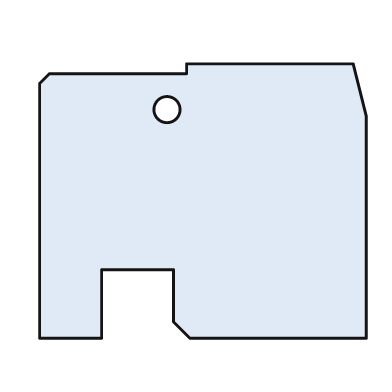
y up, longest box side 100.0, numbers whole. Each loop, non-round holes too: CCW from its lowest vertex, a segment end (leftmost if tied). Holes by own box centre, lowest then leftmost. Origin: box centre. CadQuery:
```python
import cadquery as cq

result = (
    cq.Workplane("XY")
    .moveTo(-50.0, -42.0)
    .lineTo(-31.0, -42.0)
    .lineTo(-31.0, -21.0)
    .lineTo(-9.0, -21.0)
    .lineTo(-9.0, -37.0)
    .lineTo(-4.0, -42.0)
    .lineTo(50.0, -42.0)
    .lineTo(50.0, 26.0)
    .lineTo(46.0, 42.0)
    .lineTo(-5.0, 42.0)
    .lineTo(-5.0, 39.0)
    .lineTo(-47.0, 39.0)
    .lineTo(-50.0, 36.0)
    .close()
    .moveTo(-11.0, 28.0)
    .circle(4.0)
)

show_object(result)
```